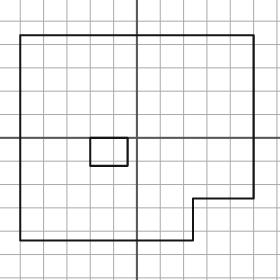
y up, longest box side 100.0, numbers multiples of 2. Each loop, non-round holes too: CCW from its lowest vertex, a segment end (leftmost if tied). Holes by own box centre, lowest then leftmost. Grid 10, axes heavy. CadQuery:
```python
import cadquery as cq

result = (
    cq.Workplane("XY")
    .moveTo(-50.0, -44.0)
    .lineTo(24.0, -44.0)
    .lineTo(24.0, -26.0)
    .lineTo(50.0, -26.0)
    .lineTo(50.0, 44.0)
    .lineTo(-50.0, 44.0)
    .close()
    .moveTo(-20.0, -12.0)
    .lineTo(-4.0, -12.0)
    .lineTo(-4.0, 0.0)
    .lineTo(-20.0, 0.0)
    .close()
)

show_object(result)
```